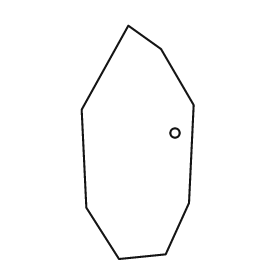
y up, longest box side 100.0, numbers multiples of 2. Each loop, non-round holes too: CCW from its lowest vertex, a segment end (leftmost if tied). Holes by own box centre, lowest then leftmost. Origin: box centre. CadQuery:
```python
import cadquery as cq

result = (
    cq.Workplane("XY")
    .moveTo(-8.0, -50.0)
    .lineTo(12.0, -48.0)
    .lineTo(22.0, -26.0)
    .lineTo(24.0, 16.0)
    .lineTo(10.0, 40.0)
    .lineTo(-4.0, 50.0)
    .lineTo(-24.0, 14.0)
    .lineTo(-22.0, -28.0)
    .close()
    .moveTo(16.0, 4.0)
    .circle(2.0)
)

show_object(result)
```